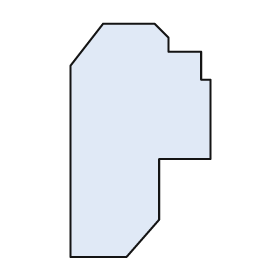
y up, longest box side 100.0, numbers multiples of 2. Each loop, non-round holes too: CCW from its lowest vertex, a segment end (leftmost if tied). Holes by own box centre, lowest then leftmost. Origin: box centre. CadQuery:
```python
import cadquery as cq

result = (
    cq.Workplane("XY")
    .moveTo(-30.0, -50.0)
    .lineTo(-6.0, -50.0)
    .lineTo(8.0, -34.0)
    .lineTo(8.0, -8.0)
    .lineTo(30.0, -8.0)
    .lineTo(30.0, 26.0)
    .lineTo(26.0, 26.0)
    .lineTo(26.0, 38.0)
    .lineTo(12.0, 38.0)
    .lineTo(12.0, 44.0)
    .lineTo(6.0, 50.0)
    .lineTo(-16.0, 50.0)
    .lineTo(-30.0, 32.0)
    .close()
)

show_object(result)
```